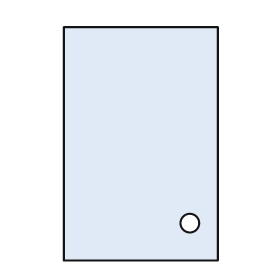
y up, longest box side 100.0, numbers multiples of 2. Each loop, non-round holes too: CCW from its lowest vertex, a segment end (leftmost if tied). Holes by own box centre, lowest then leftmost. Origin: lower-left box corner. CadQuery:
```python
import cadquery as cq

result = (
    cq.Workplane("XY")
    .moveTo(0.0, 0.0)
    .lineTo(66.0, 0.0)
    .lineTo(66.0, 100.0)
    .lineTo(0.0, 100.0)
    .close()
    .moveTo(54.0, 16.0)
    .circle(4.0)
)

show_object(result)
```